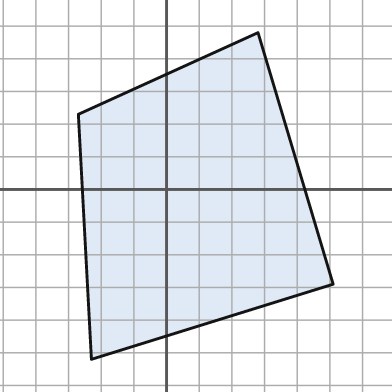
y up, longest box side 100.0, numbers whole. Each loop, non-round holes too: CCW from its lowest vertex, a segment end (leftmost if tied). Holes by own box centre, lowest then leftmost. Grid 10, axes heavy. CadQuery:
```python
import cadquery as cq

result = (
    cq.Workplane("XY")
    .moveTo(-23.0, -52.0)
    .lineTo(51.0, -29.0)
    .lineTo(28.0, 48.0)
    .lineTo(-27.0, 23.0)
    .close()
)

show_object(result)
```